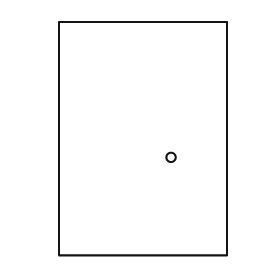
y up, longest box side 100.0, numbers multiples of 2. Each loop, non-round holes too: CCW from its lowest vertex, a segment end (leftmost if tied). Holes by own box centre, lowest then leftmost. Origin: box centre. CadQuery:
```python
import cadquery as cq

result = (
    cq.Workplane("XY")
    .moveTo(-36.0, -50.0)
    .lineTo(36.0, -50.0)
    .lineTo(36.0, 50.0)
    .lineTo(-36.0, 50.0)
    .close()
    .moveTo(12.0, -8.0)
    .circle(2.0)
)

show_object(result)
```